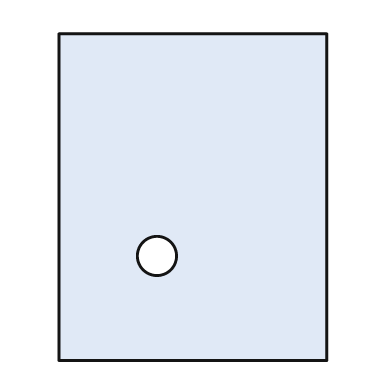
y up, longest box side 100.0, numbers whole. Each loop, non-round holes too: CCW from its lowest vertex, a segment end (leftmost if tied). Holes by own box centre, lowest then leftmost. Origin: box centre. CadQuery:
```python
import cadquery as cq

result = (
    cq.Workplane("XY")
    .moveTo(-41.0, -50.0)
    .lineTo(41.0, -50.0)
    .lineTo(41.0, 50.0)
    .lineTo(-41.0, 50.0)
    .close()
    .moveTo(-11.0, -18.0)
    .circle(6.0)
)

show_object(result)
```